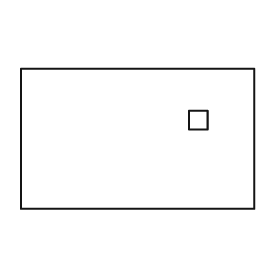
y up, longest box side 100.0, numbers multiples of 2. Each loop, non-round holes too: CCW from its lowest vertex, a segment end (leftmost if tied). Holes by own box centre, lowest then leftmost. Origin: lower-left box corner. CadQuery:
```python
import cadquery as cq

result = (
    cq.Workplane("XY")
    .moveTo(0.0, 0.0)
    .lineTo(100.0, 0.0)
    .lineTo(100.0, 60.0)
    .lineTo(0.0, 60.0)
    .close()
    .moveTo(72.0, 34.0)
    .lineTo(80.0, 34.0)
    .lineTo(80.0, 42.0)
    .lineTo(72.0, 42.0)
    .close()
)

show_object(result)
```